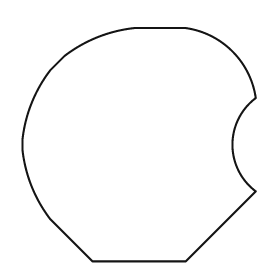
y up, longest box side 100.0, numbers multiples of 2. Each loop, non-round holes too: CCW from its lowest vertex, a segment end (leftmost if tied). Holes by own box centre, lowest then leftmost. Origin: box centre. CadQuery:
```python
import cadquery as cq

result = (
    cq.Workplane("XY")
    .moveTo(-20.0, -50.0)
    .lineTo(20.0, -50.0)
    .lineTo(50.0, -20.0)
    .threePointArc((40.0, 0.0), (50.0, 20.0))
    .threePointArc((40.0, 40.0), (20.0, 50.0))
    .lineTo(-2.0, 50.0)
    .threePointArc((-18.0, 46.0), (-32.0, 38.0))
    .lineTo(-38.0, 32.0)
    .threePointArc((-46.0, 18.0), (-50.0, 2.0))
    .lineTo(-50.0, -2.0)
    .threePointArc((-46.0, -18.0), (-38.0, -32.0))
    .close()
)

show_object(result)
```